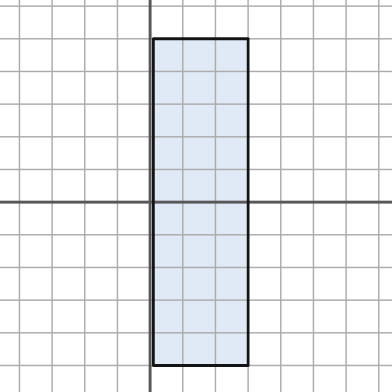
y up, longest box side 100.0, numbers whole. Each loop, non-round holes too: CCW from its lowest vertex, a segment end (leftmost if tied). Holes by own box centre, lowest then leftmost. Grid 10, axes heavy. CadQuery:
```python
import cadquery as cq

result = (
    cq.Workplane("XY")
    .moveTo(1.0, -50.0)
    .lineTo(30.0, -50.0)
    .lineTo(30.0, 50.0)
    .lineTo(1.0, 50.0)
    .close()
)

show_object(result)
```